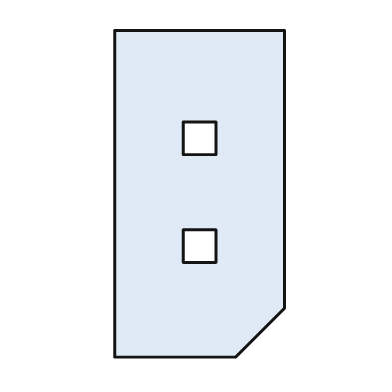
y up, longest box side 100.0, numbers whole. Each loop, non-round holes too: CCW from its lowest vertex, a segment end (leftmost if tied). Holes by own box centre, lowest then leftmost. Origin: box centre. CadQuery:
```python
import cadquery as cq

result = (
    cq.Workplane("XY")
    .moveTo(-26.0, -50.0)
    .lineTo(11.0, -50.0)
    .lineTo(26.0, -35.0)
    .lineTo(26.0, 50.0)
    .lineTo(-26.0, 50.0)
    .close()
    .moveTo(-5.0, -21.0)
    .lineTo(5.0, -21.0)
    .lineTo(5.0, -11.0)
    .lineTo(-5.0, -11.0)
    .close()
    .moveTo(-5.0, 12.0)
    .lineTo(5.0, 12.0)
    .lineTo(5.0, 22.0)
    .lineTo(-5.0, 22.0)
    .close()
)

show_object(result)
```